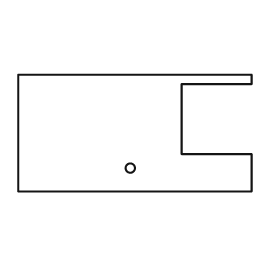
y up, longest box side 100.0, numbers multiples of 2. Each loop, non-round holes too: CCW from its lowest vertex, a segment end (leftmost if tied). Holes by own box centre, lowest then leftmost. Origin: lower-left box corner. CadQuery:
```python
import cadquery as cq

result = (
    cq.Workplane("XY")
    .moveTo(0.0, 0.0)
    .lineTo(100.0, 0.0)
    .lineTo(100.0, 16.0)
    .lineTo(70.0, 16.0)
    .lineTo(70.0, 46.0)
    .lineTo(100.0, 46.0)
    .lineTo(100.0, 50.0)
    .lineTo(0.0, 50.0)
    .close()
    .moveTo(48.0, 10.0)
    .circle(2.0)
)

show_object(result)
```